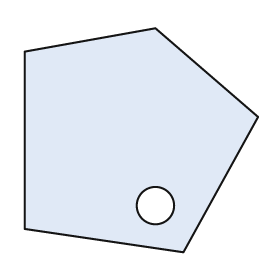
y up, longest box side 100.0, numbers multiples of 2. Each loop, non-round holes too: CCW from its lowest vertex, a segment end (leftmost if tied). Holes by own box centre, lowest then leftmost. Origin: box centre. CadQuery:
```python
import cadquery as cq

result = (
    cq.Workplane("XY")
    .moveTo(18.0, -48.0)
    .lineTo(50.0, 10.0)
    .lineTo(6.0, 48.0)
    .lineTo(-50.0, 38.0)
    .lineTo(-50.0, -38.0)
    .close()
    .moveTo(6.0, -28.0)
    .circle(8.0)
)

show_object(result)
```